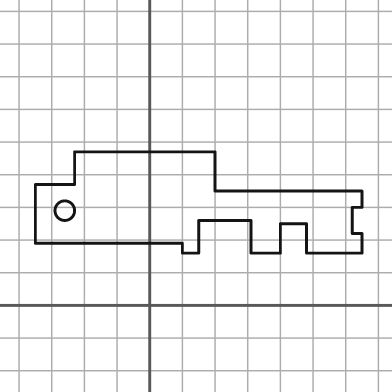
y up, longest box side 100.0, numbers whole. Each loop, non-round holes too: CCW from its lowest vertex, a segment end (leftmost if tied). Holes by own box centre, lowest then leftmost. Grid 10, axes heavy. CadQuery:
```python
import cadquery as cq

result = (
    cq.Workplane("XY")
    .moveTo(10.0, 16.0)
    .lineTo(15.0, 16.0)
    .lineTo(15.0, 26.0)
    .lineTo(31.0, 26.0)
    .lineTo(31.0, 16.0)
    .lineTo(40.0, 16.0)
    .lineTo(40.0, 25.0)
    .lineTo(48.0, 25.0)
    .lineTo(48.0, 16.0)
    .lineTo(65.0, 16.0)
    .lineTo(65.0, 22.0)
    .lineTo(62.0, 22.0)
    .lineTo(62.0, 30.0)
    .lineTo(65.0, 30.0)
    .lineTo(65.0, 35.0)
    .lineTo(20.0, 35.0)
    .lineTo(20.0, 47.0)
    .lineTo(-23.0, 47.0)
    .lineTo(-23.0, 37.0)
    .lineTo(-35.0, 37.0)
    .lineTo(-35.0, 19.0)
    .lineTo(10.0, 19.0)
    .close()
    .moveTo(-26.0, 29.0)
    .circle(3.0)
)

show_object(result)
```